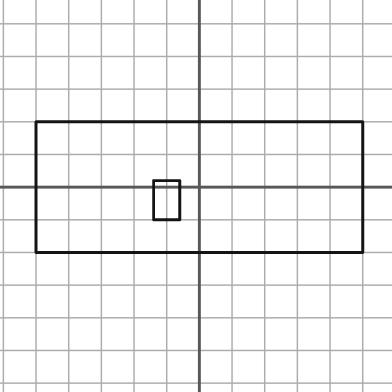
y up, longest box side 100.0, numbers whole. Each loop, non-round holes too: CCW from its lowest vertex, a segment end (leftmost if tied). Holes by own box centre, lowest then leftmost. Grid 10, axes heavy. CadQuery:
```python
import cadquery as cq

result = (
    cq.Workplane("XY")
    .moveTo(-50.0, -20.0)
    .lineTo(50.0, -20.0)
    .lineTo(50.0, 20.0)
    .lineTo(-50.0, 20.0)
    .close()
    .moveTo(-14.0, -10.0)
    .lineTo(-6.0, -10.0)
    .lineTo(-6.0, 2.0)
    .lineTo(-14.0, 2.0)
    .close()
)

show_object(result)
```